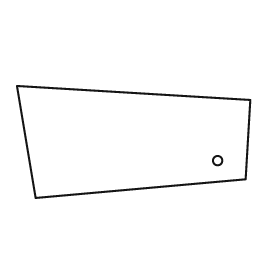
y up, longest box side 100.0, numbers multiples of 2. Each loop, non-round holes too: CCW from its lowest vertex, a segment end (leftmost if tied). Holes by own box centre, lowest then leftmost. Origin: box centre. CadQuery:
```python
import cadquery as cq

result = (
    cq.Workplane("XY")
    .moveTo(-42.0, -24.0)
    .lineTo(48.0, -16.0)
    .lineTo(50.0, 18.0)
    .lineTo(-50.0, 24.0)
    .close()
    .moveTo(36.0, -8.0)
    .circle(2.0)
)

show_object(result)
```